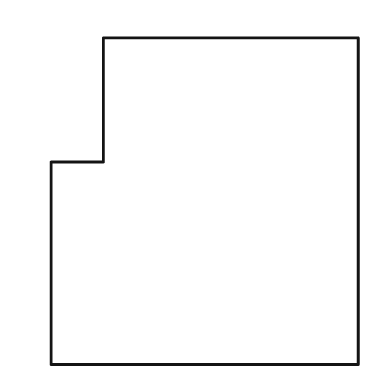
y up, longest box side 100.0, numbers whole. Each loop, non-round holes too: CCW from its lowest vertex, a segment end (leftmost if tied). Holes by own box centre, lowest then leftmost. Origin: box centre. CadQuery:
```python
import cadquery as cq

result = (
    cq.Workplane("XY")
    .moveTo(-47.0, -50.0)
    .lineTo(47.0, -50.0)
    .lineTo(47.0, 50.0)
    .lineTo(-31.0, 50.0)
    .lineTo(-31.0, 12.0)
    .lineTo(-47.0, 12.0)
    .close()
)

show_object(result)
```